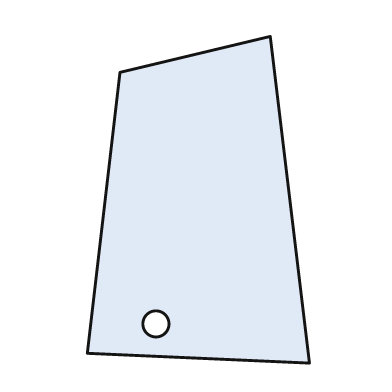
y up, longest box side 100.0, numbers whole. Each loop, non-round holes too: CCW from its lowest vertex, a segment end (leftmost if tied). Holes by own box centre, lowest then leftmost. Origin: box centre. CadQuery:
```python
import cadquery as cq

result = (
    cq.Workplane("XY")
    .moveTo(34.0, -50.0)
    .lineTo(22.0, 50.0)
    .lineTo(-24.0, 39.0)
    .lineTo(-34.0, -47.0)
    .close()
    .moveTo(-13.0, -38.0)
    .circle(4.0)
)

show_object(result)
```